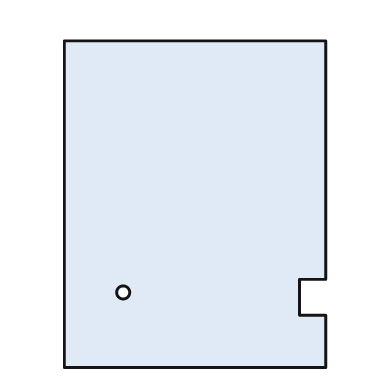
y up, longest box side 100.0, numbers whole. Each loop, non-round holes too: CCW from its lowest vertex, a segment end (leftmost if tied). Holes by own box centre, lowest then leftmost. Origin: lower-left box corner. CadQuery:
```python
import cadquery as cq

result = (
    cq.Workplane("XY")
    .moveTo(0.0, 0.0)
    .lineTo(80.0, 0.0)
    .lineTo(80.0, 16.0)
    .lineTo(72.0, 16.0)
    .lineTo(72.0, 27.0)
    .lineTo(80.0, 27.0)
    .lineTo(80.0, 100.0)
    .lineTo(0.0, 100.0)
    .close()
    .moveTo(18.0, 23.0)
    .circle(2.0)
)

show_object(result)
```